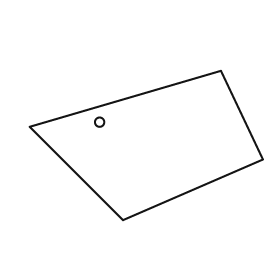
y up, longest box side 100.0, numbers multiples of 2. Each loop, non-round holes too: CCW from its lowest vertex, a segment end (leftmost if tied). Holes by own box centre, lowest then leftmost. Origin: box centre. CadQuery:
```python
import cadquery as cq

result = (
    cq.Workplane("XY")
    .moveTo(-10.0, -32.0)
    .lineTo(50.0, -6.0)
    .lineTo(32.0, 32.0)
    .lineTo(-50.0, 8.0)
    .close()
    .moveTo(-20.0, 10.0)
    .circle(2.0)
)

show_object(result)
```